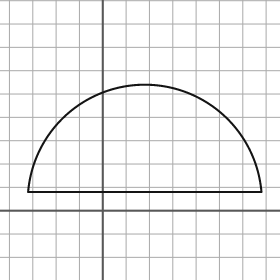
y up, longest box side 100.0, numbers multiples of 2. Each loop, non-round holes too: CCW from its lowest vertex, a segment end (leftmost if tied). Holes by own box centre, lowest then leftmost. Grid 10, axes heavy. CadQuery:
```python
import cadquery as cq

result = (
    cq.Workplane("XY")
    .moveTo(-32.0, 8.0)
    .lineTo(68.0, 8.0)
    .threePointArc((18.0, 54.0), (-32.0, 8.0))
    .close()
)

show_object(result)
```